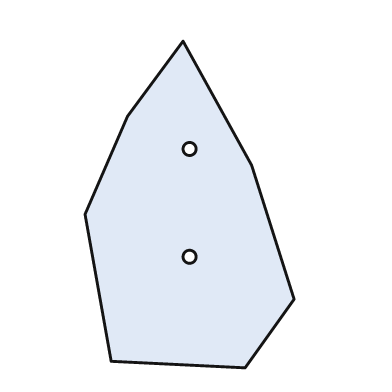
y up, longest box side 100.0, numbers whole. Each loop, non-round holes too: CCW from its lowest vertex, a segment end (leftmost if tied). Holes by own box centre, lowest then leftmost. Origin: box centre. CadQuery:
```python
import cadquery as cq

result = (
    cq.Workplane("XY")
    .moveTo(17.0, -50.0)
    .lineTo(32.0, -29.0)
    .lineTo(19.0, 12.0)
    .lineTo(-2.0, 50.0)
    .lineTo(-19.0, 27.0)
    .lineTo(-32.0, -3.0)
    .lineTo(-24.0, -48.0)
    .close()
    .moveTo(0.0, -16.0)
    .circle(2.0)
    .moveTo(0.0, 17.0)
    .circle(2.0)
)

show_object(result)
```